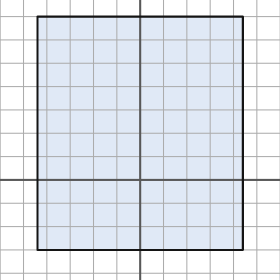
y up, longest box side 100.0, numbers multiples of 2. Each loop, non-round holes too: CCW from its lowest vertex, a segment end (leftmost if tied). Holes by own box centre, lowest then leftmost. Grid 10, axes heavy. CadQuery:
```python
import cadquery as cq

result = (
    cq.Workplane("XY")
    .moveTo(-44.0, -30.0)
    .lineTo(44.0, -30.0)
    .lineTo(44.0, 70.0)
    .lineTo(-44.0, 70.0)
    .close()
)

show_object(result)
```